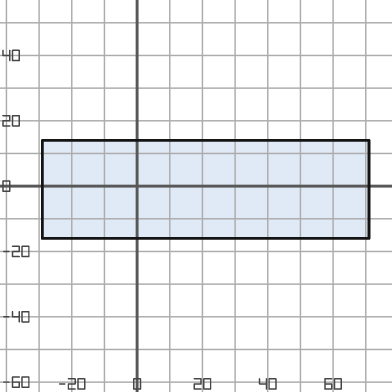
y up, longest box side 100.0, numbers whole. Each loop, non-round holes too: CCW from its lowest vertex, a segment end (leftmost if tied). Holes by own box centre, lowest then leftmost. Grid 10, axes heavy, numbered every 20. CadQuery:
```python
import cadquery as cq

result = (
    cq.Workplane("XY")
    .moveTo(-29.0, -16.0)
    .lineTo(71.0, -16.0)
    .lineTo(71.0, 14.0)
    .lineTo(-29.0, 14.0)
    .close()
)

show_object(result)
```